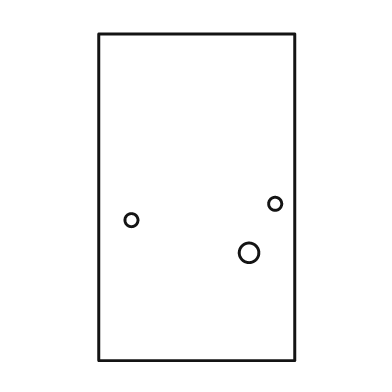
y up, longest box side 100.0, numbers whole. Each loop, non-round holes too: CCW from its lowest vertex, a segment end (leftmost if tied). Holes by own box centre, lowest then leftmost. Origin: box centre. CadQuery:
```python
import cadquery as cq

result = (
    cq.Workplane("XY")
    .moveTo(-30.0, -50.0)
    .lineTo(30.0, -50.0)
    .lineTo(30.0, 50.0)
    .lineTo(-30.0, 50.0)
    .close()
    .moveTo(16.0, -17.0)
    .circle(3.0)
    .moveTo(-20.0, -7.0)
    .circle(2.0)
    .moveTo(24.0, -2.0)
    .circle(2.0)
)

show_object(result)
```